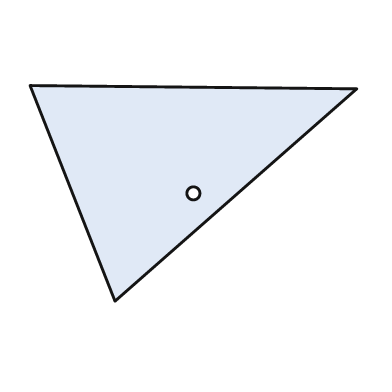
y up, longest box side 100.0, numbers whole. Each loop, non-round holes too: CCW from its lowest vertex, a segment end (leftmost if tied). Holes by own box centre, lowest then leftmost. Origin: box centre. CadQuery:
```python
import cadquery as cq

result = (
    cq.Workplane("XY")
    .moveTo(-24.0, -33.0)
    .lineTo(50.0, 32.0)
    .lineTo(-50.0, 33.0)
    .close()
    .moveTo(0.0, 0.0)
    .circle(2.0)
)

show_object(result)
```